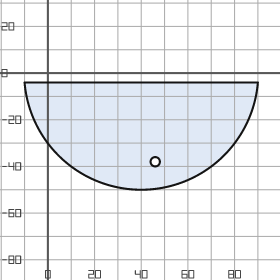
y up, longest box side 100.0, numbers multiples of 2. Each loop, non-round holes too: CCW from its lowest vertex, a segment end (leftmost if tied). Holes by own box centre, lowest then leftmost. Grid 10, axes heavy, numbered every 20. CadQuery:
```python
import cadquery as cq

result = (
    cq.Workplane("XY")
    .moveTo(-10.0, -4.0)
    .threePointArc((40.0, -50.0), (90.0, -4.0))
    .close()
    .moveTo(46.0, -38.0)
    .circle(2.0)
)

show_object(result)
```